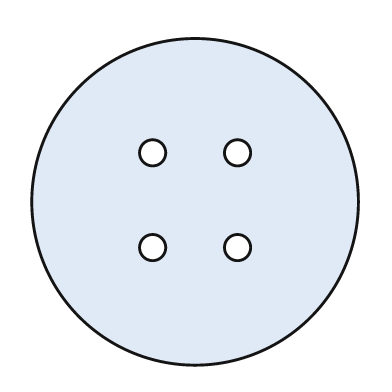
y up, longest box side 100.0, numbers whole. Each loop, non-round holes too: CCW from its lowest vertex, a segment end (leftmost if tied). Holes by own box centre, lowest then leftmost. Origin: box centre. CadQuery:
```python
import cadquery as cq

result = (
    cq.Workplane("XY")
    .moveTo(0.0, 0.0)
    .circle(50.0)
    .moveTo(-13.0, -14.0)
    .circle(4.0)
    .moveTo(13.0, -14.0)
    .circle(4.0)
    .moveTo(-13.0, 15.0)
    .circle(4.0)
    .moveTo(13.0, 15.0)
    .circle(4.0)
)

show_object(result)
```